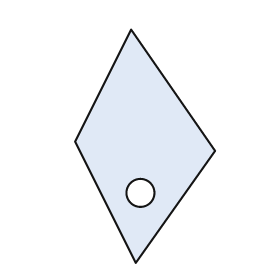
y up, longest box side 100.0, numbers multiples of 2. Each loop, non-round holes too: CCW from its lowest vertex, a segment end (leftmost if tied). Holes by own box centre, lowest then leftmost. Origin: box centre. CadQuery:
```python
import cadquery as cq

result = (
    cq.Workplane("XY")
    .moveTo(-4.0, -50.0)
    .lineTo(30.0, -2.0)
    .lineTo(-6.0, 50.0)
    .lineTo(-30.0, 2.0)
    .close()
    .moveTo(-2.0, -20.0)
    .circle(6.0)
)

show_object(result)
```